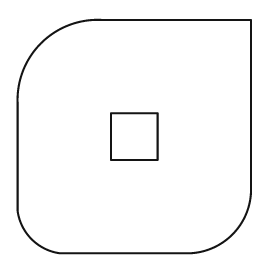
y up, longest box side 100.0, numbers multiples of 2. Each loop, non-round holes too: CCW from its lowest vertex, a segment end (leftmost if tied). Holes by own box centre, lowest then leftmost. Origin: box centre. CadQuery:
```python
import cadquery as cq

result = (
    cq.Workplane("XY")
    .moveTo(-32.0, -50.0)
    .lineTo(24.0, -50.0)
    .threePointArc((42.0, -42.0), (50.0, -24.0))
    .lineTo(50.0, 50.0)
    .lineTo(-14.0, 50.0)
    .threePointArc((-40.0, 40.0), (-50.0, 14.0))
    .lineTo(-50.0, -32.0)
    .threePointArc((-44.0, -44.0), (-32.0, -50.0))
    .close()
    .moveTo(-10.0, -10.0)
    .lineTo(10.0, -10.0)
    .lineTo(10.0, 10.0)
    .lineTo(-10.0, 10.0)
    .close()
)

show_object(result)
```